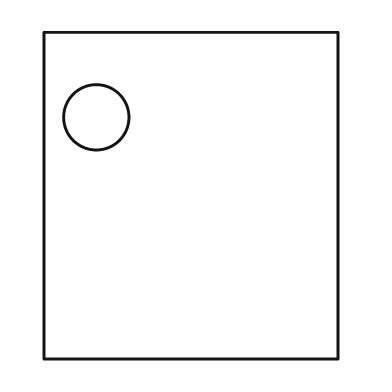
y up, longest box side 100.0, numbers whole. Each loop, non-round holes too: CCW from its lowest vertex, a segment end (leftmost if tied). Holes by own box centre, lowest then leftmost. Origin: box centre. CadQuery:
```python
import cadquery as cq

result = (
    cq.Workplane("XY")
    .moveTo(-45.0, -50.0)
    .lineTo(45.0, -50.0)
    .lineTo(45.0, 50.0)
    .lineTo(-45.0, 50.0)
    .close()
    .moveTo(-29.0, 24.0)
    .circle(10.0)
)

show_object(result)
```